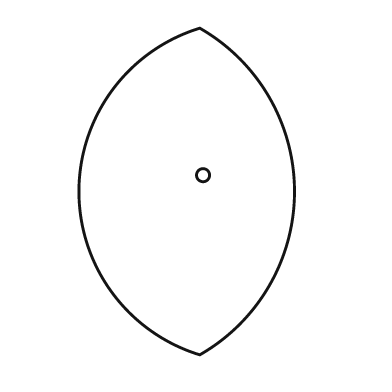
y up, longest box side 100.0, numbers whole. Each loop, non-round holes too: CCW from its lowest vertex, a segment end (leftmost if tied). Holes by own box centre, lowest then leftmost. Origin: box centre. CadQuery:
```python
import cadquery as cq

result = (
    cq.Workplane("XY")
    .moveTo(4.0, -50.0)
    .threePointArc((33.0, 0.0), (4.0, 50.0))
    .threePointArc((-33.0, 0.0), (4.0, -50.0))
    .close()
    .moveTo(5.0, 5.0)
    .circle(2.0)
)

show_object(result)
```